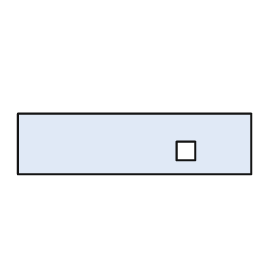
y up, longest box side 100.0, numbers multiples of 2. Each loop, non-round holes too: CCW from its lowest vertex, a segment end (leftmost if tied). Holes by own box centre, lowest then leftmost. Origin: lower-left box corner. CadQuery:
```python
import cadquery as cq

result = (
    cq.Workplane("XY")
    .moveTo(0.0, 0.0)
    .lineTo(100.0, 0.0)
    .lineTo(100.0, 26.0)
    .lineTo(0.0, 26.0)
    .close()
    .moveTo(68.0, 6.0)
    .lineTo(76.0, 6.0)
    .lineTo(76.0, 14.0)
    .lineTo(68.0, 14.0)
    .close()
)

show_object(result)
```